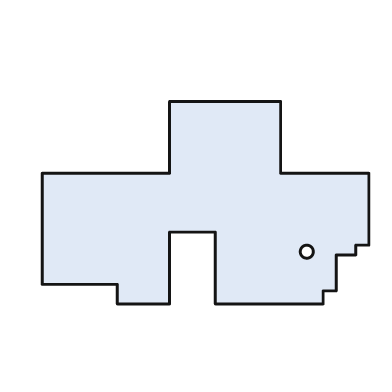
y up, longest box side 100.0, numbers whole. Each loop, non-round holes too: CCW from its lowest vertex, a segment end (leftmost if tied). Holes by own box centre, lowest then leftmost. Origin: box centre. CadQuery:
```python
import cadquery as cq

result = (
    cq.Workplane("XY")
    .moveTo(-27.0, -31.0)
    .lineTo(-11.0, -31.0)
    .lineTo(-11.0, -9.0)
    .lineTo(3.0, -9.0)
    .lineTo(3.0, -31.0)
    .lineTo(36.0, -31.0)
    .lineTo(36.0, -27.0)
    .lineTo(40.0, -27.0)
    .lineTo(40.0, -16.0)
    .lineTo(46.0, -16.0)
    .lineTo(46.0, -13.0)
    .lineTo(50.0, -13.0)
    .lineTo(50.0, 9.0)
    .lineTo(23.0, 9.0)
    .lineTo(23.0, 31.0)
    .lineTo(-11.0, 31.0)
    .lineTo(-11.0, 9.0)
    .lineTo(-50.0, 9.0)
    .lineTo(-50.0, -25.0)
    .lineTo(-27.0, -25.0)
    .close()
    .moveTo(31.0, -15.0)
    .circle(2.0)
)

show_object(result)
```